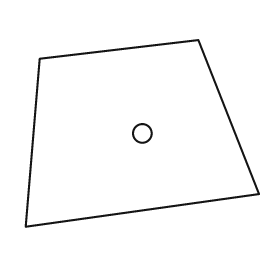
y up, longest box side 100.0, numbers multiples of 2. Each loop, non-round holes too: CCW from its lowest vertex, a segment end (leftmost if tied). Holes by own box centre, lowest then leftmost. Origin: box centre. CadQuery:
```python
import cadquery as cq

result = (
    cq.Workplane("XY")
    .moveTo(-50.0, -40.0)
    .lineTo(50.0, -26.0)
    .lineTo(24.0, 40.0)
    .lineTo(-44.0, 32.0)
    .close()
    .moveTo(0.0, 0.0)
    .circle(4.0)
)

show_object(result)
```